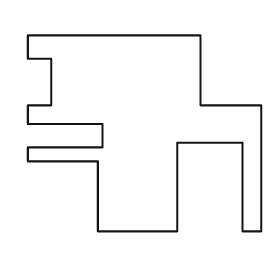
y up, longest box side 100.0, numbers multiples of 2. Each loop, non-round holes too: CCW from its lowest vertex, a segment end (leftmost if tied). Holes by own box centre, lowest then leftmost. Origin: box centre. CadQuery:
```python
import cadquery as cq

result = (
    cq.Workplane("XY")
    .moveTo(-20.0, -42.0)
    .lineTo(14.0, -42.0)
    .lineTo(14.0, -4.0)
    .lineTo(42.0, -4.0)
    .lineTo(42.0, -42.0)
    .lineTo(50.0, -42.0)
    .lineTo(50.0, 12.0)
    .lineTo(24.0, 12.0)
    .lineTo(24.0, 42.0)
    .lineTo(-50.0, 42.0)
    .lineTo(-50.0, 32.0)
    .lineTo(-40.0, 32.0)
    .lineTo(-40.0, 12.0)
    .lineTo(-50.0, 12.0)
    .lineTo(-50.0, 4.0)
    .lineTo(-18.0, 4.0)
    .lineTo(-18.0, -6.0)
    .lineTo(-50.0, -6.0)
    .lineTo(-50.0, -12.0)
    .lineTo(-20.0, -12.0)
    .close()
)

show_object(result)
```